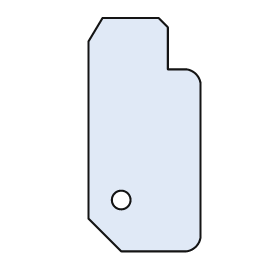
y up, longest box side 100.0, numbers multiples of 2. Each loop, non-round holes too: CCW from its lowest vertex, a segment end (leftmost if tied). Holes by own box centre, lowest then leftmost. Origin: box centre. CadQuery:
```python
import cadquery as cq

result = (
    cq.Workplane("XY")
    .moveTo(-10.0, -50.0)
    .lineTo(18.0, -50.0)
    .threePointArc((22.0, -48.0), (24.0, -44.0))
    .lineTo(24.0, 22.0)
    .threePointArc((22.0, 26.0), (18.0, 28.0))
    .lineTo(10.0, 28.0)
    .lineTo(10.0, 46.0)
    .lineTo(6.0, 50.0)
    .lineTo(-18.0, 50.0)
    .lineTo(-24.0, 40.0)
    .lineTo(-24.0, -36.0)
    .close()
    .moveTo(-10.0, -28.0)
    .circle(4.0)
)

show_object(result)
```